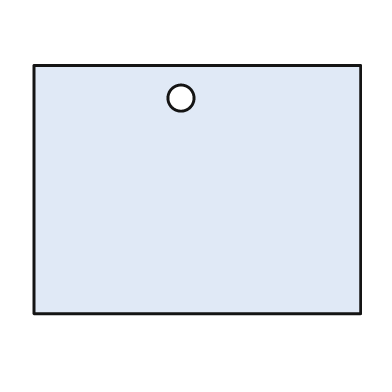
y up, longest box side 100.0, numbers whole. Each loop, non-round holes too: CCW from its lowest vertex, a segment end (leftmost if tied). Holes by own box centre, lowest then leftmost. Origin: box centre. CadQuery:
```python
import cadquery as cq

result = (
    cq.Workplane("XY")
    .moveTo(-50.0, -38.0)
    .lineTo(50.0, -38.0)
    .lineTo(50.0, 38.0)
    .lineTo(-50.0, 38.0)
    .close()
    .moveTo(-5.0, 28.0)
    .circle(4.0)
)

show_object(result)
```